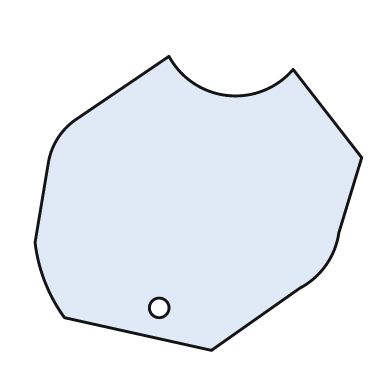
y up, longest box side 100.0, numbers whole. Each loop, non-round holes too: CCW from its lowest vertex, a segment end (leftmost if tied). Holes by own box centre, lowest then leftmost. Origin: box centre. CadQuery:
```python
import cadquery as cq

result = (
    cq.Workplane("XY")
    .moveTo(4.0, -45.0)
    .lineTo(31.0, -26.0)
    .threePointArc((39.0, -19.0), (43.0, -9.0))
    .lineTo(50.0, 14.0)
    .lineTo(29.0, 41.0)
    .threePointArc((9.0, 33.0), (-9.0, 45.0))
    .lineTo(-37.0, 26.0)
    .threePointArc((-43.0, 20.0), (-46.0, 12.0))
    .lineTo(-50.0, -12.0)
    .threePointArc((-47.0, -24.0), (-41.0, -35.0))
    .close()
    .moveTo(-12.0, -32.0)
    .circle(3.0)
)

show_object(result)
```